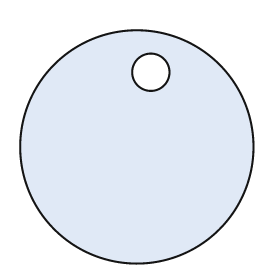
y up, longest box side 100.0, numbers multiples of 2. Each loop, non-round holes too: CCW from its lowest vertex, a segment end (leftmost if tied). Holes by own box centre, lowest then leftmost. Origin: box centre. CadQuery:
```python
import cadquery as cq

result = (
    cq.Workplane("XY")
    .moveTo(0.0, 0.0)
    .circle(50.0)
    .moveTo(6.0, 32.0)
    .circle(8.0)
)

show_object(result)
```